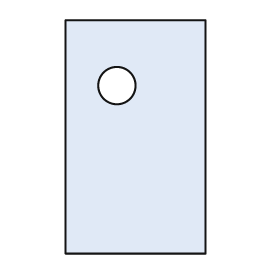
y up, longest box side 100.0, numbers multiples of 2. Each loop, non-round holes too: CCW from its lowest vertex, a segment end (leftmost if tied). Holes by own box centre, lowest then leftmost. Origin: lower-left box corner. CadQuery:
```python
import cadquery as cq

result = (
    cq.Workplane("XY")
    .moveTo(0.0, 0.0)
    .lineTo(60.0, 0.0)
    .lineTo(60.0, 100.0)
    .lineTo(0.0, 100.0)
    .close()
    .moveTo(22.0, 72.0)
    .circle(8.0)
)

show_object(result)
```